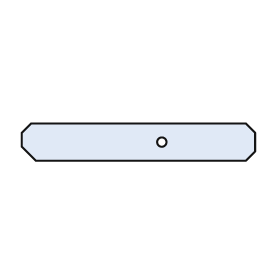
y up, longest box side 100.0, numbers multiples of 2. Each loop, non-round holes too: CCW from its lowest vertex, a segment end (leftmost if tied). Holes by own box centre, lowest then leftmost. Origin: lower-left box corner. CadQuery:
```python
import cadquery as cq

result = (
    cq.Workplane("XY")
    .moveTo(6.0, 0.0)
    .lineTo(96.0, 0.0)
    .lineTo(100.0, 4.0)
    .lineTo(100.0, 12.0)
    .lineTo(96.0, 16.0)
    .lineTo(4.0, 16.0)
    .lineTo(0.0, 12.0)
    .lineTo(0.0, 6.0)
    .close()
    .moveTo(60.0, 8.0)
    .circle(2.0)
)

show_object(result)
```